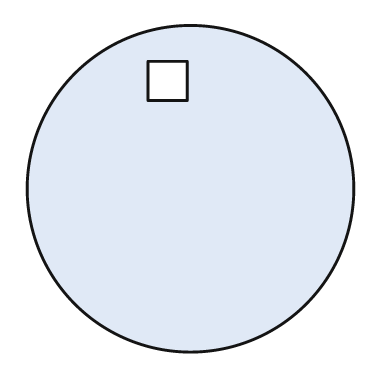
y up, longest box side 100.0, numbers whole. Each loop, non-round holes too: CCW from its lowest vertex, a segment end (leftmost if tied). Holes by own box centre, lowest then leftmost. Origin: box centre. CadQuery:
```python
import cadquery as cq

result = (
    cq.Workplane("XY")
    .moveTo(0.0, 0.0)
    .circle(50.0)
    .moveTo(-13.0, 27.0)
    .lineTo(-1.0, 27.0)
    .lineTo(-1.0, 39.0)
    .lineTo(-13.0, 39.0)
    .close()
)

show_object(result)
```